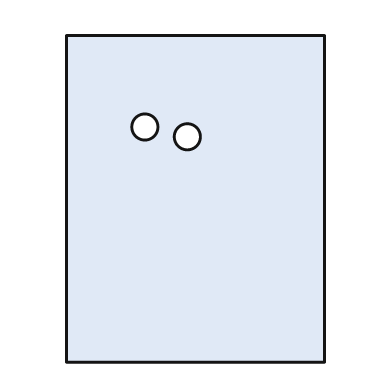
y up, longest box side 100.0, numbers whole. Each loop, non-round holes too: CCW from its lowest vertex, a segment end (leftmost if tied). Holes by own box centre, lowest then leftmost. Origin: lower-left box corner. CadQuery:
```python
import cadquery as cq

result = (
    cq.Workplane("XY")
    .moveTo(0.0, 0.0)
    .lineTo(79.0, 0.0)
    .lineTo(79.0, 100.0)
    .lineTo(0.0, 100.0)
    .close()
    .moveTo(37.0, 69.0)
    .circle(4.0)
    .moveTo(24.0, 72.0)
    .circle(4.0)
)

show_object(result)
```